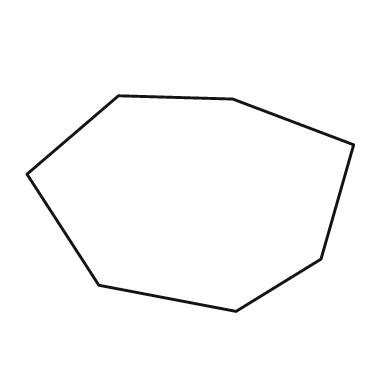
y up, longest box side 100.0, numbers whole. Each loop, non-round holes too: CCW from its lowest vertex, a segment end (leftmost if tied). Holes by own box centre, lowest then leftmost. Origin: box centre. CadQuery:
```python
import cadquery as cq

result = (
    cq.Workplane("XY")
    .moveTo(14.0, -33.0)
    .lineTo(40.0, -17.0)
    .lineTo(50.0, 18.0)
    .lineTo(13.0, 32.0)
    .lineTo(-22.0, 33.0)
    .lineTo(-50.0, 9.0)
    .lineTo(-28.0, -25.0)
    .close()
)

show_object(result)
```